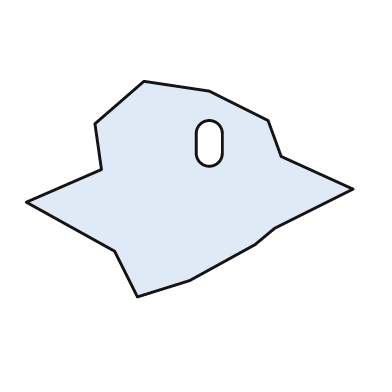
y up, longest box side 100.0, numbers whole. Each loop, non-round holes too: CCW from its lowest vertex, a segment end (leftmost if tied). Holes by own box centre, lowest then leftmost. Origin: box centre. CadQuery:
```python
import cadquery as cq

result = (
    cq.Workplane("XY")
    .moveTo(-16.0, -33.0)
    .lineTo(0.0, -28.0)
    .lineTo(20.0, -17.0)
    .lineTo(26.0, -12.0)
    .lineTo(50.0, 0.0)
    .lineTo(28.0, 10.0)
    .lineTo(24.0, 21.0)
    .lineTo(6.0, 30.0)
    .lineTo(-14.0, 33.0)
    .lineTo(-29.0, 20.0)
    .lineTo(-27.0, 6.0)
    .lineTo(-50.0, -4.0)
    .lineTo(-23.0, -19.0)
    .close()
    .moveTo(2.0, 11.0)
    .threePointArc((6.0, 7.0), (10.0, 11.0))
    .lineTo(10.0, 17.0)
    .threePointArc((6.0, 21.0), (2.0, 17.0))
    .close()
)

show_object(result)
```